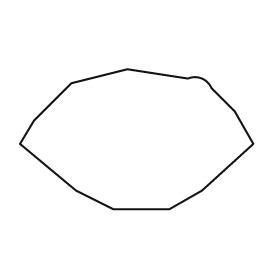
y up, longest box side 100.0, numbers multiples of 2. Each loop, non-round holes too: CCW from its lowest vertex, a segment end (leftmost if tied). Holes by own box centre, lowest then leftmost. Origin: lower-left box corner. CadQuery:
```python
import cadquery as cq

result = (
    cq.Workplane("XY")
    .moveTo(40.0, 0.0)
    .lineTo(64.0, 0.0)
    .lineTo(78.0, 8.0)
    .lineTo(100.0, 28.0)
    .lineTo(92.0, 42.0)
    .lineTo(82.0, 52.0)
    .threePointArc((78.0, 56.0), (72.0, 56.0))
    .lineTo(46.0, 60.0)
    .lineTo(22.0, 54.0)
    .lineTo(6.0, 38.0)
    .lineTo(0.0, 28.0)
    .lineTo(24.0, 8.0)
    .close()
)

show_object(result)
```